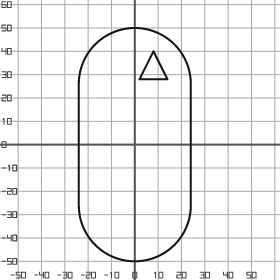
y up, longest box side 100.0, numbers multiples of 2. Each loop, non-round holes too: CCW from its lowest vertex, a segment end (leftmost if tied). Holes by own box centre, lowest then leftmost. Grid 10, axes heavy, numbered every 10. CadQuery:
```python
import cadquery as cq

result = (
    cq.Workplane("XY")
    .moveTo(-24.0, -26.0)
    .threePointArc((0.0, -50.0), (24.0, -26.0))
    .lineTo(24.0, 26.0)
    .threePointArc((0.0, 50.0), (-24.0, 26.0))
    .close()
    .moveTo(2.0, 28.0)
    .lineTo(14.0, 28.0)
    .lineTo(8.0, 40.0)
    .close()
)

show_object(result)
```